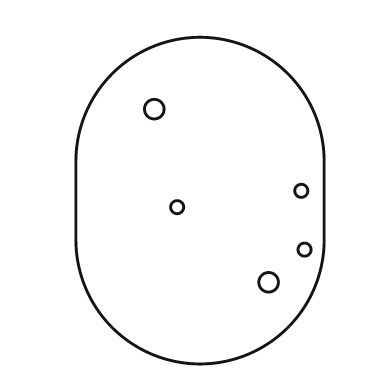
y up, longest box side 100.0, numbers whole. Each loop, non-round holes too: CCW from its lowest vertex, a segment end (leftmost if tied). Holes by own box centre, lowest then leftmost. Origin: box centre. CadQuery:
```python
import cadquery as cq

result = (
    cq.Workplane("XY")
    .moveTo(-38.0, -12.0)
    .threePointArc((0.0, -50.0), (38.0, -12.0))
    .lineTo(38.0, 12.0)
    .threePointArc((0.0, 50.0), (-38.0, 12.0))
    .close()
    .moveTo(21.0, -25.0)
    .circle(3.0)
    .moveTo(32.0, -15.0)
    .circle(2.0)
    .moveTo(-7.0, -2.0)
    .circle(2.0)
    .moveTo(31.0, 3.0)
    .circle(2.0)
    .moveTo(-14.0, 28.0)
    .circle(3.0)
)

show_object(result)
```